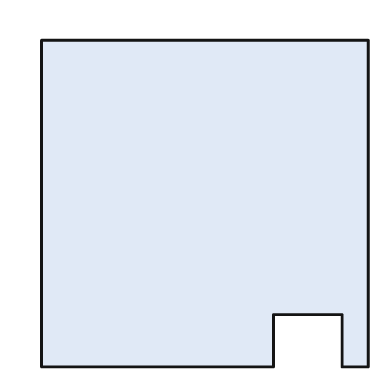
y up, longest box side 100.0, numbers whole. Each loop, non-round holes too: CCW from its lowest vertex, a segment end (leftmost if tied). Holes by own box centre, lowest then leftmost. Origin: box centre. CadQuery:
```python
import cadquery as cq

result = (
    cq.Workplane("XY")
    .moveTo(-50.0, -50.0)
    .lineTo(21.0, -50.0)
    .lineTo(21.0, -34.0)
    .lineTo(42.0, -34.0)
    .lineTo(42.0, -50.0)
    .lineTo(50.0, -50.0)
    .lineTo(50.0, 50.0)
    .lineTo(-50.0, 50.0)
    .close()
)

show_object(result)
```